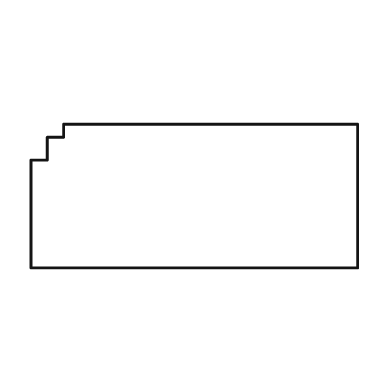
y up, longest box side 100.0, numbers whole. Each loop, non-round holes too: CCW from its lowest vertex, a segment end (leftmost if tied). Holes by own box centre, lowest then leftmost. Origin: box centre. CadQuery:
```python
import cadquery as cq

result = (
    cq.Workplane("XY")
    .moveTo(-50.0, -22.0)
    .lineTo(50.0, -22.0)
    .lineTo(50.0, 22.0)
    .lineTo(-40.0, 22.0)
    .lineTo(-40.0, 18.0)
    .lineTo(-45.0, 18.0)
    .lineTo(-45.0, 11.0)
    .lineTo(-50.0, 11.0)
    .close()
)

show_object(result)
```